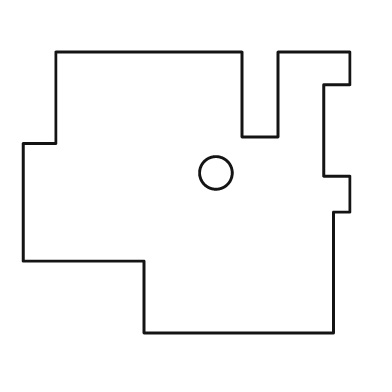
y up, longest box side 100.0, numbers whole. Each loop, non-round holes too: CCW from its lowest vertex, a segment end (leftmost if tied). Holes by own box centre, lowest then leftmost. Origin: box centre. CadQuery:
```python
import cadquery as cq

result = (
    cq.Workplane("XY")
    .moveTo(-13.0, -43.0)
    .lineTo(45.0, -43.0)
    .lineTo(45.0, -6.0)
    .lineTo(50.0, -6.0)
    .lineTo(50.0, 5.0)
    .lineTo(42.0, 5.0)
    .lineTo(42.0, 33.0)
    .lineTo(50.0, 33.0)
    .lineTo(50.0, 43.0)
    .lineTo(28.0, 43.0)
    .lineTo(28.0, 17.0)
    .lineTo(17.0, 17.0)
    .lineTo(17.0, 43.0)
    .lineTo(-40.0, 43.0)
    .lineTo(-40.0, 15.0)
    .lineTo(-50.0, 15.0)
    .lineTo(-50.0, -21.0)
    .lineTo(-13.0, -21.0)
    .close()
    .moveTo(9.0, 6.0)
    .circle(5.0)
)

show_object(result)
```